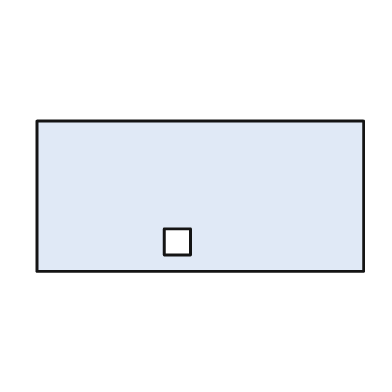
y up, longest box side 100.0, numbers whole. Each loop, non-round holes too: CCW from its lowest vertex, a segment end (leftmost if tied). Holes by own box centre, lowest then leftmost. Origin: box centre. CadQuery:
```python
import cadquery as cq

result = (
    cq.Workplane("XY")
    .moveTo(-50.0, -23.0)
    .lineTo(50.0, -23.0)
    .lineTo(50.0, 23.0)
    .lineTo(-50.0, 23.0)
    .close()
    .moveTo(-11.0, -18.0)
    .lineTo(-3.0, -18.0)
    .lineTo(-3.0, -10.0)
    .lineTo(-11.0, -10.0)
    .close()
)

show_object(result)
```